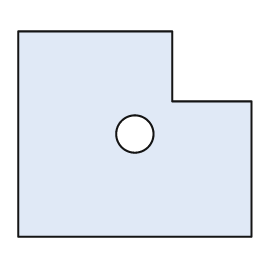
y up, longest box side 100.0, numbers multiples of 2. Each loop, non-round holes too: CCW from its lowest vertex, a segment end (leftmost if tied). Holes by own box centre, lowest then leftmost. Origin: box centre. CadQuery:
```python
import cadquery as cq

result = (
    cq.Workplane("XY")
    .moveTo(-50.0, -44.0)
    .lineTo(50.0, -44.0)
    .lineTo(50.0, 14.0)
    .lineTo(16.0, 14.0)
    .lineTo(16.0, 44.0)
    .lineTo(-50.0, 44.0)
    .close()
    .moveTo(0.0, 0.0)
    .circle(8.0)
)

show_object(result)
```